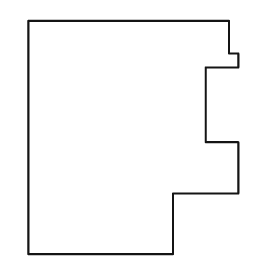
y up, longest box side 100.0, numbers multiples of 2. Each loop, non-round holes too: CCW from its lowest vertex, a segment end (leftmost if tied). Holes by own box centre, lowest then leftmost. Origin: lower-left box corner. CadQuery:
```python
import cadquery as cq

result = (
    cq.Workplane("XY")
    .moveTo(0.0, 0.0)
    .lineTo(62.0, 0.0)
    .lineTo(62.0, 26.0)
    .lineTo(90.0, 26.0)
    .lineTo(90.0, 48.0)
    .lineTo(76.0, 48.0)
    .lineTo(76.0, 80.0)
    .lineTo(90.0, 80.0)
    .lineTo(90.0, 86.0)
    .lineTo(86.0, 86.0)
    .lineTo(86.0, 100.0)
    .lineTo(0.0, 100.0)
    .close()
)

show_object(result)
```